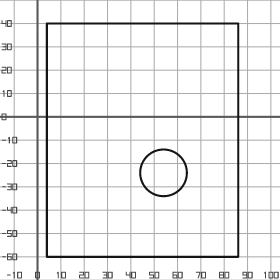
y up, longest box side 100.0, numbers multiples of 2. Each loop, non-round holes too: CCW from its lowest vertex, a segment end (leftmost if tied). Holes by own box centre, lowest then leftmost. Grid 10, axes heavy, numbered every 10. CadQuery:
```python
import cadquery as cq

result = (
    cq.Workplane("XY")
    .moveTo(4.0, -60.0)
    .lineTo(86.0, -60.0)
    .lineTo(86.0, 40.0)
    .lineTo(4.0, 40.0)
    .close()
    .moveTo(54.0, -24.0)
    .circle(10.0)
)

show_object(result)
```